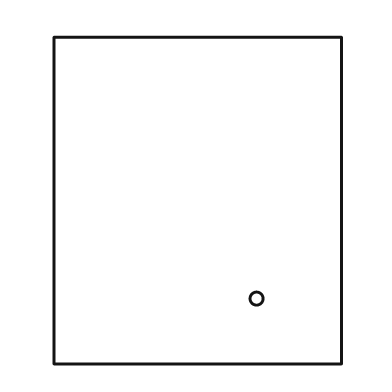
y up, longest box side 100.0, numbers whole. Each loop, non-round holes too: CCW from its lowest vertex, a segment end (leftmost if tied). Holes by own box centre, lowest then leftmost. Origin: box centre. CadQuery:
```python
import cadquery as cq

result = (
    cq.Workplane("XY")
    .moveTo(-44.0, -50.0)
    .lineTo(44.0, -50.0)
    .lineTo(44.0, 50.0)
    .lineTo(-44.0, 50.0)
    .close()
    .moveTo(18.0, -30.0)
    .circle(2.0)
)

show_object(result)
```